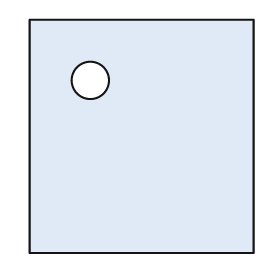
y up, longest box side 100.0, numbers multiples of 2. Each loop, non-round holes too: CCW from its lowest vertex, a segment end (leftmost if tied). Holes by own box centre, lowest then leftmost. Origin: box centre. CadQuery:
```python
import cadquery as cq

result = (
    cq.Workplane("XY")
    .moveTo(-48.0, -50.0)
    .lineTo(48.0, -50.0)
    .lineTo(48.0, 50.0)
    .lineTo(-48.0, 50.0)
    .close()
    .moveTo(-22.0, 24.0)
    .circle(8.0)
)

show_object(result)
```